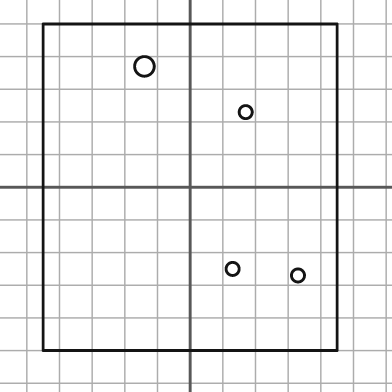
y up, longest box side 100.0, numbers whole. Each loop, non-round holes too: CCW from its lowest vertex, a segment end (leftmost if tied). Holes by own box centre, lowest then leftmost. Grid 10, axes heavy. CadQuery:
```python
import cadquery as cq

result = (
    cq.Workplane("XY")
    .moveTo(-45.0, -50.0)
    .lineTo(45.0, -50.0)
    .lineTo(45.0, 50.0)
    .lineTo(-45.0, 50.0)
    .close()
    .moveTo(33.0, -27.0)
    .circle(2.0)
    .moveTo(13.0, -25.0)
    .circle(2.0)
    .moveTo(17.0, 23.0)
    .circle(2.0)
    .moveTo(-14.0, 37.0)
    .circle(3.0)
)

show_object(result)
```